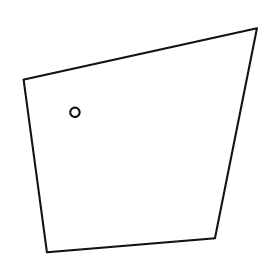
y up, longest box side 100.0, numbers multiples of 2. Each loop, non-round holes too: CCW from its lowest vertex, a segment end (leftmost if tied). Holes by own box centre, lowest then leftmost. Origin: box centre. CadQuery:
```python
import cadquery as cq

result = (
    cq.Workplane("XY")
    .moveTo(-40.0, -48.0)
    .lineTo(32.0, -42.0)
    .lineTo(50.0, 48.0)
    .lineTo(-50.0, 26.0)
    .close()
    .moveTo(-28.0, 12.0)
    .circle(2.0)
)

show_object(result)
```